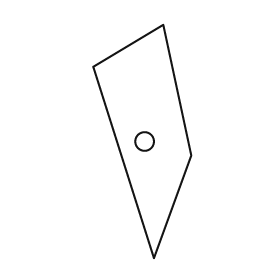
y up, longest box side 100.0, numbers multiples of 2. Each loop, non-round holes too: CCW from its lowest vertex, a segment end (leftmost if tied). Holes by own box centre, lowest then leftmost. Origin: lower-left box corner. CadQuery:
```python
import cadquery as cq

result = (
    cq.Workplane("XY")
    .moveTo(26.0, 0.0)
    .lineTo(42.0, 44.0)
    .lineTo(30.0, 100.0)
    .lineTo(0.0, 82.0)
    .close()
    .moveTo(22.0, 50.0)
    .circle(4.0)
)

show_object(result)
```